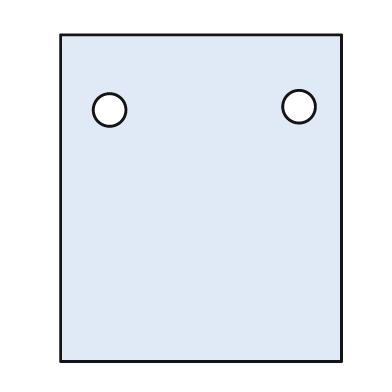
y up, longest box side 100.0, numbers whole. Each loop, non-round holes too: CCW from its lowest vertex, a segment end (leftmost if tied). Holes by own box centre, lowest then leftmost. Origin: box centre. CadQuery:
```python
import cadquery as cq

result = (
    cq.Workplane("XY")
    .moveTo(-43.0, -50.0)
    .lineTo(43.0, -50.0)
    .lineTo(43.0, 50.0)
    .lineTo(-43.0, 50.0)
    .close()
    .moveTo(-28.0, 27.0)
    .circle(5.0)
    .moveTo(30.0, 28.0)
    .circle(5.0)
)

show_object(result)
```